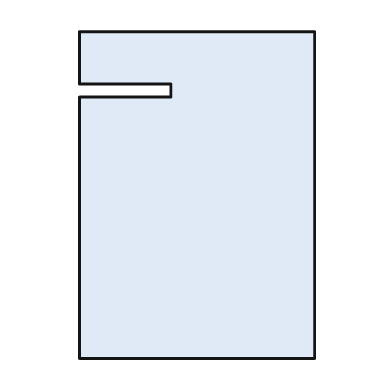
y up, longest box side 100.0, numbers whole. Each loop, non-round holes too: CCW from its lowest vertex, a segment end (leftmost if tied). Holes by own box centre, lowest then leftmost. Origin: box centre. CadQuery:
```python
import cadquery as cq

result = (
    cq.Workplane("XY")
    .moveTo(-36.0, -50.0)
    .lineTo(36.0, -50.0)
    .lineTo(36.0, 50.0)
    .lineTo(-36.0, 50.0)
    .lineTo(-36.0, 34.0)
    .lineTo(-8.0, 34.0)
    .lineTo(-8.0, 30.0)
    .lineTo(-36.0, 30.0)
    .close()
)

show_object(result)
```